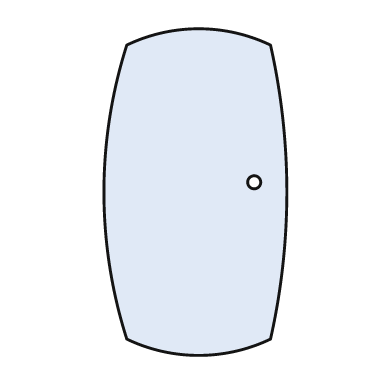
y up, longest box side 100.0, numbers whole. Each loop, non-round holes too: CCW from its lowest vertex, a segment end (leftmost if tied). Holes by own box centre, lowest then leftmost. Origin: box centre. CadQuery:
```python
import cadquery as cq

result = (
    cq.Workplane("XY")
    .moveTo(-21.0, -45.0)
    .threePointArc((1.0, -50.0), (23.0, -45.0))
    .threePointArc((28.0, 0.0), (23.0, 45.0))
    .threePointArc((1.0, 50.0), (-21.0, 45.0))
    .threePointArc((-28.0, 0.0), (-21.0, -45.0))
    .close()
    .moveTo(18.0, 3.0)
    .circle(2.0)
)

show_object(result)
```